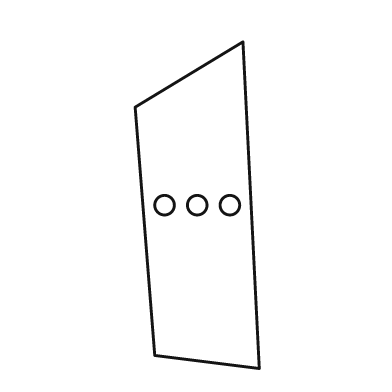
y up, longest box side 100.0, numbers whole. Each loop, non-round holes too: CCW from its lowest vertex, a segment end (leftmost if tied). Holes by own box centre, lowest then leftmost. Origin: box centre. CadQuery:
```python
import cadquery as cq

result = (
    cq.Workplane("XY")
    .moveTo(19.0, -50.0)
    .lineTo(14.0, 50.0)
    .lineTo(-19.0, 30.0)
    .lineTo(-13.0, -46.0)
    .close()
    .moveTo(-10.0, 0.0)
    .circle(3.0)
    .moveTo(0.0, 0.0)
    .circle(3.0)
    .moveTo(10.0, 0.0)
    .circle(3.0)
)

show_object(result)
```